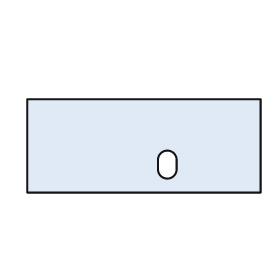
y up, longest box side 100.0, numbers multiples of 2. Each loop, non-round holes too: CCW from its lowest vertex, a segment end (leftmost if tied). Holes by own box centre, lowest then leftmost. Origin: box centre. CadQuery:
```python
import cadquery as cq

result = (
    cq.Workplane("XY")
    .moveTo(-50.0, -20.0)
    .lineTo(50.0, -20.0)
    .lineTo(50.0, 20.0)
    .lineTo(-50.0, 20.0)
    .close()
    .moveTo(6.0, -10.0)
    .threePointArc((10.0, -14.0), (14.0, -10.0))
    .lineTo(14.0, -6.0)
    .threePointArc((10.0, -2.0), (6.0, -6.0))
    .close()
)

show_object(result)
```